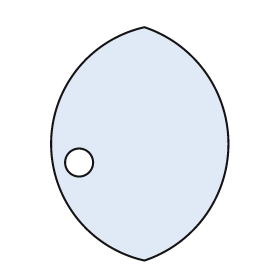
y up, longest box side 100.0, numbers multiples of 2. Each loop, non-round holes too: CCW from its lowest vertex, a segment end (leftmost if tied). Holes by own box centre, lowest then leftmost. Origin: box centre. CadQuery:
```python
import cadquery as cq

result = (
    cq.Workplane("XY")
    .moveTo(2.0, -50.0)
    .threePointArc((38.0, 0.0), (2.0, 50.0))
    .threePointArc((-38.0, 0.0), (2.0, -50.0))
    .close()
    .moveTo(-26.0, -8.0)
    .circle(6.0)
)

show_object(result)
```